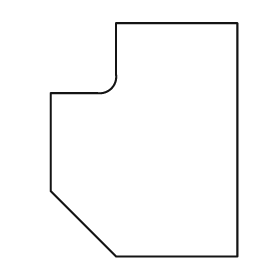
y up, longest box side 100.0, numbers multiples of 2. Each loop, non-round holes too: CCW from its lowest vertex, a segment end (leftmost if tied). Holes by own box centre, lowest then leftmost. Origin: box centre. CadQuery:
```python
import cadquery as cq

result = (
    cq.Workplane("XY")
    .moveTo(-12.0, -50.0)
    .lineTo(40.0, -50.0)
    .lineTo(40.0, 50.0)
    .lineTo(-12.0, 50.0)
    .lineTo(-12.0, 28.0)
    .threePointArc((-14.0, 22.0), (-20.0, 20.0))
    .lineTo(-40.0, 20.0)
    .lineTo(-40.0, -22.0)
    .close()
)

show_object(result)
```